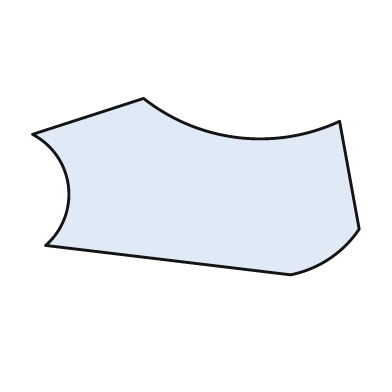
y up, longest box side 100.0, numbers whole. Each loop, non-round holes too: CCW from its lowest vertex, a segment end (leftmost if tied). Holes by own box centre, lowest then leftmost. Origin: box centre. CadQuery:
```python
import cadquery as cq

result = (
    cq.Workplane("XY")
    .moveTo(29.0, -27.0)
    .threePointArc((41.0, -22.0), (50.0, -13.0))
    .lineTo(44.0, 20.0)
    .threePointArc((13.0, 15.0), (-16.0, 27.0))
    .lineTo(-50.0, 16.0)
    .threePointArc((-39.0, 0.0), (-46.0, -18.0))
    .close()
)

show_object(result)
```